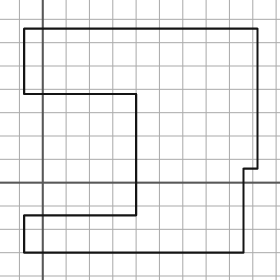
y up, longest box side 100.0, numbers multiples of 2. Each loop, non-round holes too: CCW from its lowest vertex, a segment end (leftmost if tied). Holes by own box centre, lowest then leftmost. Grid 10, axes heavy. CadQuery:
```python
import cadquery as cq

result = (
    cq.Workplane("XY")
    .moveTo(-8.0, -30.0)
    .lineTo(86.0, -30.0)
    .lineTo(86.0, 6.0)
    .lineTo(92.0, 6.0)
    .lineTo(92.0, 66.0)
    .lineTo(-8.0, 66.0)
    .lineTo(-8.0, 38.0)
    .lineTo(40.0, 38.0)
    .lineTo(40.0, -14.0)
    .lineTo(-8.0, -14.0)
    .close()
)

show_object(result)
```